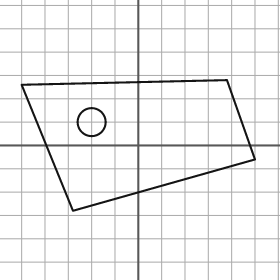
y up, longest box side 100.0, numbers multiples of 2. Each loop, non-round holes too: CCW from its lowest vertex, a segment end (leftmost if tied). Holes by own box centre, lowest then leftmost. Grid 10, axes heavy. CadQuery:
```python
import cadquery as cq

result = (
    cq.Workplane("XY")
    .moveTo(-28.0, -28.0)
    .lineTo(50.0, -6.0)
    .lineTo(38.0, 28.0)
    .lineTo(-50.0, 26.0)
    .close()
    .moveTo(-20.0, 10.0)
    .circle(6.0)
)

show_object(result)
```